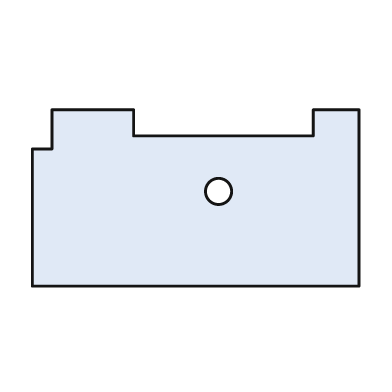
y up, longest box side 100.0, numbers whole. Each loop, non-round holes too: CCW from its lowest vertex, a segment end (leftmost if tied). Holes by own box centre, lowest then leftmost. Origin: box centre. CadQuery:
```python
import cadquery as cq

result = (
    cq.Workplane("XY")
    .moveTo(-50.0, -27.0)
    .lineTo(50.0, -27.0)
    .lineTo(50.0, 27.0)
    .lineTo(36.0, 27.0)
    .lineTo(36.0, 19.0)
    .lineTo(-19.0, 19.0)
    .lineTo(-19.0, 27.0)
    .lineTo(-44.0, 27.0)
    .lineTo(-44.0, 15.0)
    .lineTo(-50.0, 15.0)
    .close()
    .moveTo(7.0, 2.0)
    .circle(4.0)
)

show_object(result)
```